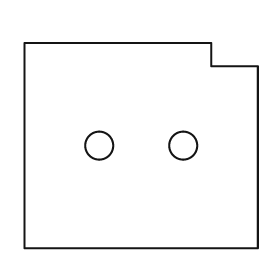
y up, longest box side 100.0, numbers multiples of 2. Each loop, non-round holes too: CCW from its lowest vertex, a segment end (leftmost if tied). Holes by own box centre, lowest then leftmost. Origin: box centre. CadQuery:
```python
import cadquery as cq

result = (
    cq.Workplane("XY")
    .moveTo(-50.0, -44.0)
    .lineTo(50.0, -44.0)
    .lineTo(50.0, 34.0)
    .lineTo(30.0, 34.0)
    .lineTo(30.0, 44.0)
    .lineTo(-50.0, 44.0)
    .close()
    .moveTo(-18.0, 0.0)
    .circle(6.0)
    .moveTo(18.0, 0.0)
    .circle(6.0)
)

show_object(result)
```